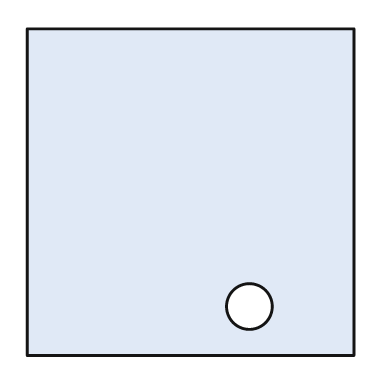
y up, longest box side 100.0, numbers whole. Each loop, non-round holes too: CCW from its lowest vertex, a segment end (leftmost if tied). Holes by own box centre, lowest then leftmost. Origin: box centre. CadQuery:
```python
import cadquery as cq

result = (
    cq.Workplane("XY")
    .moveTo(-50.0, -50.0)
    .lineTo(50.0, -50.0)
    .lineTo(50.0, 50.0)
    .lineTo(-50.0, 50.0)
    .close()
    .moveTo(18.0, -35.0)
    .circle(7.0)
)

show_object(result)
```